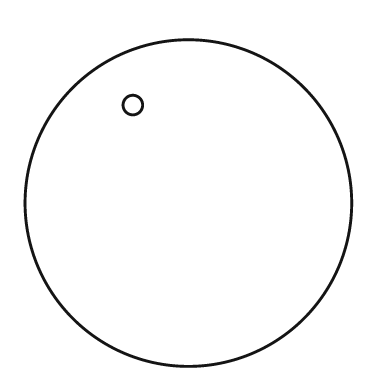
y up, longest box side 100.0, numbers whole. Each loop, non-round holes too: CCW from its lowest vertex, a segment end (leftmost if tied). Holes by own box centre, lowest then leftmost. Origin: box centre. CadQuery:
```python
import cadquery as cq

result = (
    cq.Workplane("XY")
    .moveTo(0.0, 0.0)
    .circle(50.0)
    .moveTo(-17.0, 30.0)
    .circle(3.0)
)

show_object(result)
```